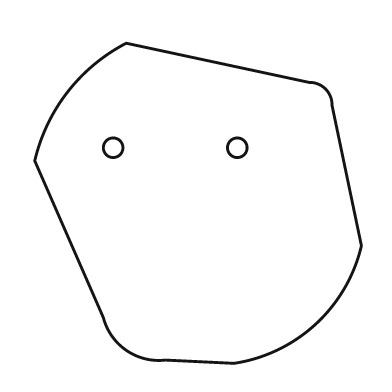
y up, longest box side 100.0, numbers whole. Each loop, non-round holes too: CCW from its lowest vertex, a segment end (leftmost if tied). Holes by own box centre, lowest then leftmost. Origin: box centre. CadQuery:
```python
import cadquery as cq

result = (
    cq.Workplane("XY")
    .moveTo(11.0, -49.0)
    .threePointArc((36.0, -37.0), (50.0, -13.0))
    .lineTo(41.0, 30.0)
    .threePointArc((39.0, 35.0), (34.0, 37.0))
    .lineTo(-22.0, 49.0)
    .threePointArc((-40.0, 34.0), (-50.0, 13.0))
    .lineTo(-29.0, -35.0)
    .threePointArc((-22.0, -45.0), (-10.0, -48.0))
    .close()
    .moveTo(-26.0, 17.0)
    .circle(3.0)
    .moveTo(12.0, 17.0)
    .circle(3.0)
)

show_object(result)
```